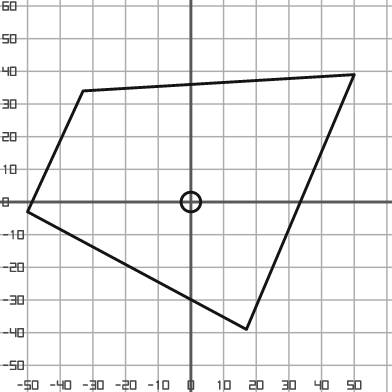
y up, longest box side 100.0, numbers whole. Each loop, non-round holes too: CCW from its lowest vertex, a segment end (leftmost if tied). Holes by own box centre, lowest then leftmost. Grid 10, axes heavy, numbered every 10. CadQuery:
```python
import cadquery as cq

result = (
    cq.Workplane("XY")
    .moveTo(17.0, -39.0)
    .lineTo(50.0, 39.0)
    .lineTo(-33.0, 34.0)
    .lineTo(-50.0, -3.0)
    .close()
    .moveTo(0.0, 0.0)
    .circle(3.0)
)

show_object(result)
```